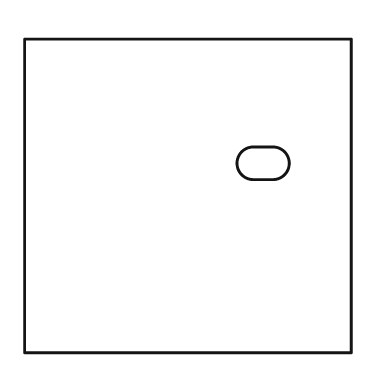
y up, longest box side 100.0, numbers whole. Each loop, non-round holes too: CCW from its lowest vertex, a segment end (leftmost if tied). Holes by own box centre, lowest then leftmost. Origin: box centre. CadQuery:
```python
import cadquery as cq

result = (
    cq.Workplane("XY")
    .moveTo(-50.0, -48.0)
    .lineTo(50.0, -48.0)
    .lineTo(50.0, 48.0)
    .lineTo(-50.0, 48.0)
    .close()
    .moveTo(20.0, 5.0)
    .lineTo(26.0, 5.0)
    .threePointArc((31.0, 10.0), (26.0, 15.0))
    .lineTo(20.0, 15.0)
    .threePointArc((15.0, 10.0), (20.0, 5.0))
    .close()
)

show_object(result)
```